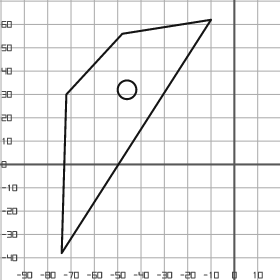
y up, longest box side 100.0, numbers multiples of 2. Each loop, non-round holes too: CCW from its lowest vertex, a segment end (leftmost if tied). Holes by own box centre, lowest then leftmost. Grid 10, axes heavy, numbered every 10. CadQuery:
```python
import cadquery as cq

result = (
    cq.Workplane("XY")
    .moveTo(-74.0, -38.0)
    .lineTo(-10.0, 62.0)
    .lineTo(-48.0, 56.0)
    .lineTo(-72.0, 30.0)
    .close()
    .moveTo(-46.0, 32.0)
    .circle(4.0)
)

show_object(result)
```